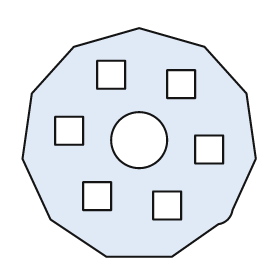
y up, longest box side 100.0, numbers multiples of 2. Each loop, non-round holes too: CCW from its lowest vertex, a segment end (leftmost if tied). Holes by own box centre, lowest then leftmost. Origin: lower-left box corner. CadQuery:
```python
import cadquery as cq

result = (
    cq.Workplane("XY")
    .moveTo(36.0, 0.0)
    .lineTo(64.0, 0.0)
    .lineTo(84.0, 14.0)
    .threePointArc((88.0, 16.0), (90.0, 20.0))
    .lineTo(100.0, 42.0)
    .lineTo(96.0, 70.0)
    .lineTo(78.0, 90.0)
    .lineTo(50.0, 98.0)
    .lineTo(22.0, 90.0)
    .lineTo(4.0, 70.0)
    .lineTo(0.0, 42.0)
    .lineTo(12.0, 16.0)
    .close()
    .moveTo(56.0, 16.0)
    .lineTo(68.0, 16.0)
    .lineTo(68.0, 28.0)
    .lineTo(56.0, 28.0)
    .close()
    .moveTo(26.0, 20.0)
    .lineTo(38.0, 20.0)
    .lineTo(38.0, 32.0)
    .lineTo(26.0, 32.0)
    .close()
    .moveTo(74.0, 40.0)
    .lineTo(86.0, 40.0)
    .lineTo(86.0, 52.0)
    .lineTo(74.0, 52.0)
    .close()
    .moveTo(50.0, 50.0)
    .circle(12.0)
    .moveTo(14.0, 48.0)
    .lineTo(26.0, 48.0)
    .lineTo(26.0, 60.0)
    .lineTo(14.0, 60.0)
    .close()
    .moveTo(62.0, 68.0)
    .lineTo(74.0, 68.0)
    .lineTo(74.0, 80.0)
    .lineTo(62.0, 80.0)
    .close()
    .moveTo(32.0, 72.0)
    .lineTo(44.0, 72.0)
    .lineTo(44.0, 84.0)
    .lineTo(32.0, 84.0)
    .close()
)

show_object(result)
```